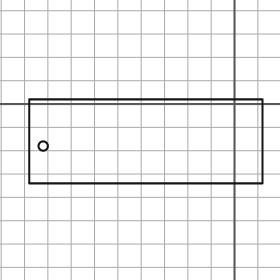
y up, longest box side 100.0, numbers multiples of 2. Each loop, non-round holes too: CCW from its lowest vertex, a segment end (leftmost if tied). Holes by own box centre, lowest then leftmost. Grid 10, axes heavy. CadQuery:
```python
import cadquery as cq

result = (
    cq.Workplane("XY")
    .moveTo(-88.0, -34.0)
    .lineTo(12.0, -34.0)
    .lineTo(12.0, 2.0)
    .lineTo(-88.0, 2.0)
    .close()
    .moveTo(-82.0, -18.0)
    .circle(2.0)
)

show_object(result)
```